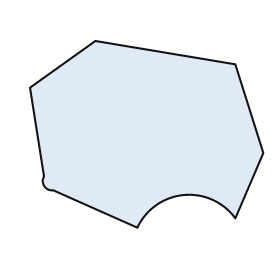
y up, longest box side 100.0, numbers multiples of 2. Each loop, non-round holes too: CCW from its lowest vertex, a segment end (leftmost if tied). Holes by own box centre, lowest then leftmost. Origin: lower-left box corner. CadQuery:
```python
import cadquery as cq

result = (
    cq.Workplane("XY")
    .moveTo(46.0, 0.0)
    .threePointArc((66.0, 14.0), (88.0, 4.0))
    .lineTo(100.0, 32.0)
    .lineTo(88.0, 70.0)
    .lineTo(28.0, 80.0)
    .lineTo(0.0, 60.0)
    .lineTo(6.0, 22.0)
    .threePointArc((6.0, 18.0), (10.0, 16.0))
    .close()
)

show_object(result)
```